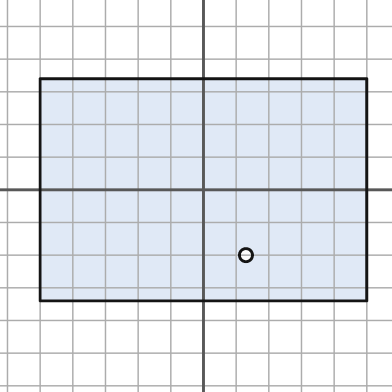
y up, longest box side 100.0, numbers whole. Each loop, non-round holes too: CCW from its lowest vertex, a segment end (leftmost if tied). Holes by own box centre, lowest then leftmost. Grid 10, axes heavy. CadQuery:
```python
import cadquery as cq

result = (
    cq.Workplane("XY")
    .moveTo(-50.0, -34.0)
    .lineTo(50.0, -34.0)
    .lineTo(50.0, 34.0)
    .lineTo(-50.0, 34.0)
    .close()
    .moveTo(13.0, -20.0)
    .circle(2.0)
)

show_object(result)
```